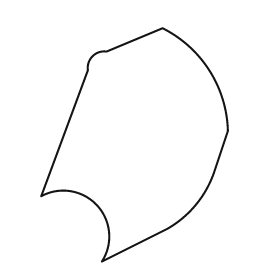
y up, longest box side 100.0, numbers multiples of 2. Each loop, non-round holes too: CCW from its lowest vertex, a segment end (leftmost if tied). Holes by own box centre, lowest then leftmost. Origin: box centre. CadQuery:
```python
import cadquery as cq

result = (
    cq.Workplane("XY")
    .moveTo(-14.0, -50.0)
    .lineTo(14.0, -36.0)
    .threePointArc((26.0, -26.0), (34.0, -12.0))
    .lineTo(40.0, 6.0)
    .threePointArc((32.0, 32.0), (12.0, 50.0))
    .lineTo(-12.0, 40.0)
    .threePointArc((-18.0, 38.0), (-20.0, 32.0))
    .lineTo(-40.0, -22.0)
    .threePointArc((-16.0, -26.0), (-14.0, -50.0))
    .close()
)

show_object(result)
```